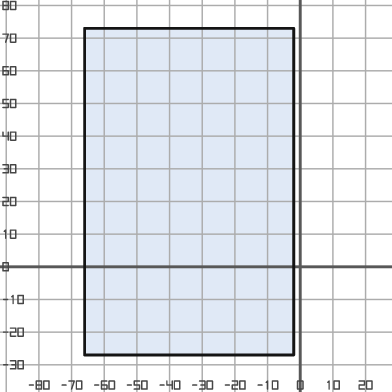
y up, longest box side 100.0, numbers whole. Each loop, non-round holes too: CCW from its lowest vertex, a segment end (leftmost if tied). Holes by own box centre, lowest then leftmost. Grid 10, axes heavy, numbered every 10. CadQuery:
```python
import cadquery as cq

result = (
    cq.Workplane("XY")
    .moveTo(-66.0, -27.0)
    .lineTo(-2.0, -27.0)
    .lineTo(-2.0, 73.0)
    .lineTo(-66.0, 73.0)
    .close()
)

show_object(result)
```